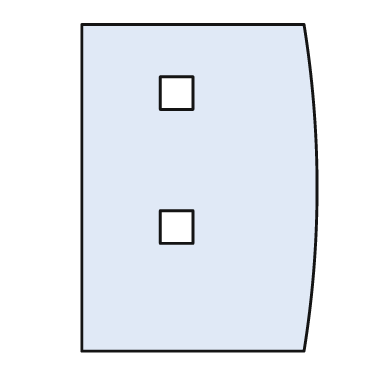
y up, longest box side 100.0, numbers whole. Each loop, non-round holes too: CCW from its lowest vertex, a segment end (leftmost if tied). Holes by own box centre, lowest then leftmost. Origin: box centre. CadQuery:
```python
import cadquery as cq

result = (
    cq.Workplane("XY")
    .moveTo(-36.0, -50.0)
    .lineTo(32.0, -50.0)
    .threePointArc((36.0, 0.0), (32.0, 50.0))
    .lineTo(-36.0, 50.0)
    .close()
    .moveTo(-12.0, -17.0)
    .lineTo(-2.0, -17.0)
    .lineTo(-2.0, -7.0)
    .lineTo(-12.0, -7.0)
    .close()
    .moveTo(-12.0, 24.0)
    .lineTo(-2.0, 24.0)
    .lineTo(-2.0, 34.0)
    .lineTo(-12.0, 34.0)
    .close()
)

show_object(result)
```